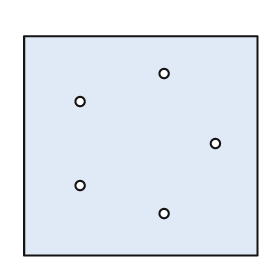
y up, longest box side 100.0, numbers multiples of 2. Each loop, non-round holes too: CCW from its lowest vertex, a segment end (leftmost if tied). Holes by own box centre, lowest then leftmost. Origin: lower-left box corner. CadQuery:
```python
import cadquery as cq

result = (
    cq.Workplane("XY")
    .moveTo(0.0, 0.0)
    .lineTo(100.0, 0.0)
    .lineTo(100.0, 94.0)
    .lineTo(0.0, 94.0)
    .close()
    .moveTo(60.0, 18.0)
    .circle(2.0)
    .moveTo(24.0, 30.0)
    .circle(2.0)
    .moveTo(82.0, 48.0)
    .circle(2.0)
    .moveTo(24.0, 66.0)
    .circle(2.0)
    .moveTo(60.0, 78.0)
    .circle(2.0)
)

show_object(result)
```